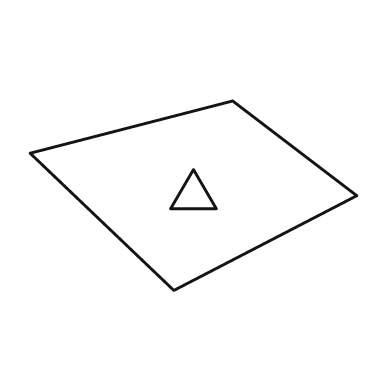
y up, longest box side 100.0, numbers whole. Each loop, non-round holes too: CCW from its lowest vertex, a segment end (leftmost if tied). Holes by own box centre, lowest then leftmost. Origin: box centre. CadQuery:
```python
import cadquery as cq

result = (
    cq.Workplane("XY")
    .moveTo(-6.0, -29.0)
    .lineTo(50.0, 0.0)
    .lineTo(12.0, 29.0)
    .lineTo(-50.0, 13.0)
    .close()
    .moveTo(-7.0, -4.0)
    .lineTo(7.0, -4.0)
    .lineTo(0.0, 8.0)
    .close()
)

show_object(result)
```